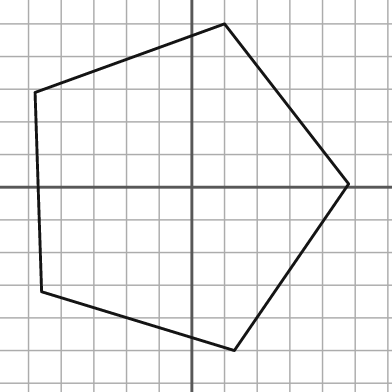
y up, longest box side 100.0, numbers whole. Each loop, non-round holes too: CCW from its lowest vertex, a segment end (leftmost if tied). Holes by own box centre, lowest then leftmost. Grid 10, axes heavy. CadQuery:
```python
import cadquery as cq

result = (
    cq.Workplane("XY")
    .moveTo(13.0, -50.0)
    .lineTo(48.0, 1.0)
    .lineTo(10.0, 50.0)
    .lineTo(-48.0, 29.0)
    .lineTo(-46.0, -32.0)
    .close()
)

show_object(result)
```